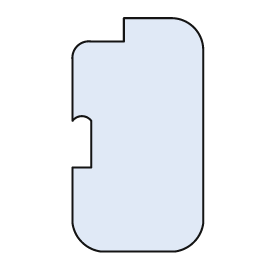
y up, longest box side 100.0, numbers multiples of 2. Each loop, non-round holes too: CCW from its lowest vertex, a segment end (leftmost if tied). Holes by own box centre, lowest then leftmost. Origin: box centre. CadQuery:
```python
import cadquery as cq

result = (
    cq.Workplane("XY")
    .moveTo(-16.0, -50.0)
    .lineTo(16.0, -50.0)
    .threePointArc((24.0, -46.0), (28.0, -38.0))
    .lineTo(28.0, 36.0)
    .threePointArc((24.0, 46.0), (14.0, 50.0))
    .lineTo(-6.0, 50.0)
    .lineTo(-6.0, 40.0)
    .lineTo(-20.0, 40.0)
    .threePointArc((-26.0, 38.0), (-28.0, 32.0))
    .lineTo(-28.0, 6.0)
    .threePointArc((-24.0, 8.0), (-20.0, 6.0))
    .lineTo(-20.0, -14.0)
    .lineTo(-28.0, -14.0)
    .lineTo(-28.0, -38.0)
    .threePointArc((-24.0, -46.0), (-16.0, -50.0))
    .close()
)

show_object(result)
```